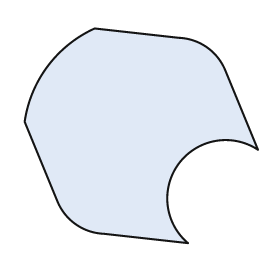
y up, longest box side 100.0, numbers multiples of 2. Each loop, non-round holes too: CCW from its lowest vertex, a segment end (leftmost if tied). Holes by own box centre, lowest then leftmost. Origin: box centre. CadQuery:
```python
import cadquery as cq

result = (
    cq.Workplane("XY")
    .moveTo(20.0, -46.0)
    .threePointArc((16.0, -12.0), (50.0, -6.0))
    .lineTo(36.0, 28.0)
    .threePointArc((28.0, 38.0), (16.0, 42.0))
    .lineTo(-20.0, 46.0)
    .threePointArc((-40.0, 30.0), (-50.0, 6.0))
    .lineTo(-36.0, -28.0)
    .threePointArc((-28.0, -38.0), (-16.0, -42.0))
    .close()
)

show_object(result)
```